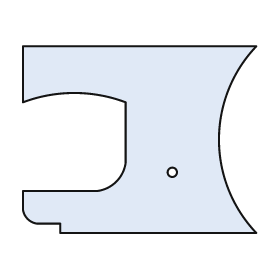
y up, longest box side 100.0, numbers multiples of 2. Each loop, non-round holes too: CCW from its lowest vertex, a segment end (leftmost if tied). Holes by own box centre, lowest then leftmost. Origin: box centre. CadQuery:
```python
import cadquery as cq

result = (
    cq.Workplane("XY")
    .moveTo(-34.0, -40.0)
    .lineTo(50.0, -40.0)
    .threePointArc((34.0, 0.0), (50.0, 40.0))
    .lineTo(-50.0, 40.0)
    .lineTo(-50.0, 16.0)
    .threePointArc((-28.0, 20.0), (-6.0, 16.0))
    .lineTo(-6.0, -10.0)
    .threePointArc((-10.0, -18.0), (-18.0, -22.0))
    .lineTo(-50.0, -22.0)
    .lineTo(-50.0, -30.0)
    .threePointArc((-48.0, -34.0), (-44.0, -36.0))
    .lineTo(-34.0, -36.0)
    .close()
    .moveTo(14.0, -14.0)
    .circle(2.0)
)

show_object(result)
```